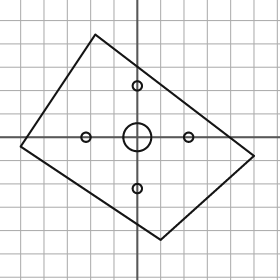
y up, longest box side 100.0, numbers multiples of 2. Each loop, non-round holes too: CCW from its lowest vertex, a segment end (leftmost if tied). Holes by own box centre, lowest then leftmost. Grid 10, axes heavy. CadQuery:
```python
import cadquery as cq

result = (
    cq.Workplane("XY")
    .moveTo(10.0, -44.0)
    .lineTo(50.0, -8.0)
    .lineTo(-18.0, 44.0)
    .lineTo(-50.0, -4.0)
    .close()
    .moveTo(0.0, -22.0)
    .circle(2.0)
    .moveTo(-22.0, 0.0)
    .circle(2.0)
    .moveTo(0.0, 0.0)
    .circle(6.0)
    .moveTo(22.0, 0.0)
    .circle(2.0)
    .moveTo(0.0, 22.0)
    .circle(2.0)
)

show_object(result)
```